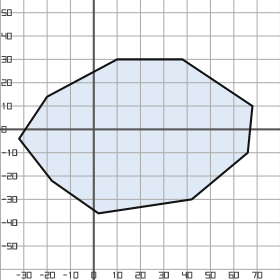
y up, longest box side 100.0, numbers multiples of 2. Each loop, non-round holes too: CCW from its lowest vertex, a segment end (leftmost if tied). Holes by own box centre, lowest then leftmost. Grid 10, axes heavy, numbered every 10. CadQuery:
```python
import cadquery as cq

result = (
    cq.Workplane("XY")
    .moveTo(2.0, -36.0)
    .lineTo(42.0, -30.0)
    .lineTo(66.0, -10.0)
    .lineTo(68.0, 10.0)
    .lineTo(38.0, 30.0)
    .lineTo(10.0, 30.0)
    .lineTo(-20.0, 14.0)
    .lineTo(-32.0, -4.0)
    .lineTo(-18.0, -22.0)
    .close()
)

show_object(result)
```